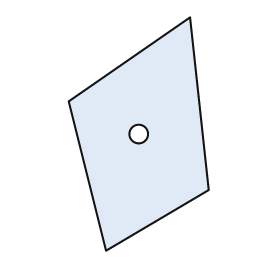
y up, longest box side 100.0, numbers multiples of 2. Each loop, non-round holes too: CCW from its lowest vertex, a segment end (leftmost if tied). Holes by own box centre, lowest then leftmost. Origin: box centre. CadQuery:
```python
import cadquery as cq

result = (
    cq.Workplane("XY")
    .moveTo(-14.0, -50.0)
    .lineTo(30.0, -24.0)
    .lineTo(22.0, 50.0)
    .lineTo(-30.0, 14.0)
    .close()
    .moveTo(0.0, 0.0)
    .circle(4.0)
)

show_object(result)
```